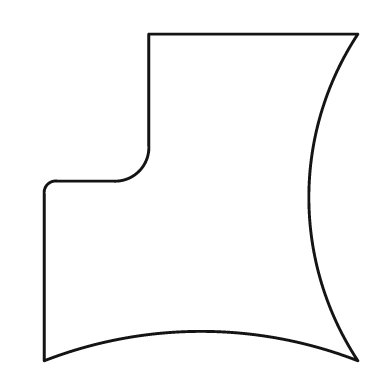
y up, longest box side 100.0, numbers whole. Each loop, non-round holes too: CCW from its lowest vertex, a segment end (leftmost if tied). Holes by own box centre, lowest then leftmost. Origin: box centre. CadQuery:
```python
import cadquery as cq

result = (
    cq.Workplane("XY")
    .moveTo(-48.0, -50.0)
    .threePointArc((0.0, -41.0), (48.0, -50.0))
    .threePointArc((33.0, 0.0), (48.0, 50.0))
    .lineTo(-16.0, 50.0)
    .lineTo(-16.0, 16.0)
    .threePointArc((-19.0, 8.0), (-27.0, 5.0))
    .lineTo(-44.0, 5.0)
    .threePointArc((-47.0, 4.0), (-48.0, 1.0))
    .close()
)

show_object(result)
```